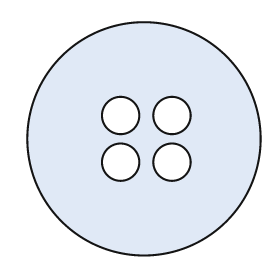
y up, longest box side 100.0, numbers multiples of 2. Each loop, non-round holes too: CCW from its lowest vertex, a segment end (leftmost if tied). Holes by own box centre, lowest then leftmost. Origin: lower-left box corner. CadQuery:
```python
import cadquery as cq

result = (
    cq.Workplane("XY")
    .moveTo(50.0, 50.0)
    .circle(50.0)
    .moveTo(40.0, 40.0)
    .circle(8.0)
    .moveTo(62.0, 40.0)
    .circle(8.0)
    .moveTo(40.0, 60.0)
    .circle(8.0)
    .moveTo(62.0, 60.0)
    .circle(8.0)
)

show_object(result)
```